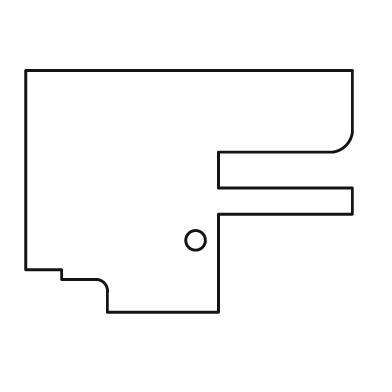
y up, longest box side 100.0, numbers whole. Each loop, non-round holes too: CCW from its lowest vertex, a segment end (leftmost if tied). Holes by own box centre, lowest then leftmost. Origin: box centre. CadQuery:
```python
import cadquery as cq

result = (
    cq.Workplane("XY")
    .moveTo(-25.0, -37.0)
    .lineTo(9.0, -37.0)
    .lineTo(9.0, -7.0)
    .lineTo(50.0, -7.0)
    .lineTo(50.0, 1.0)
    .lineTo(9.0, 1.0)
    .lineTo(9.0, 12.0)
    .lineTo(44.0, 12.0)
    .threePointArc((48.0, 14.0), (50.0, 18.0))
    .lineTo(50.0, 37.0)
    .lineTo(-50.0, 37.0)
    .lineTo(-50.0, -24.0)
    .lineTo(-39.0, -24.0)
    .lineTo(-39.0, -27.0)
    .lineTo(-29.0, -27.0)
    .threePointArc((-26.0, -28.0), (-25.0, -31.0))
    .close()
    .moveTo(2.0, -15.0)
    .circle(3.0)
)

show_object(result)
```